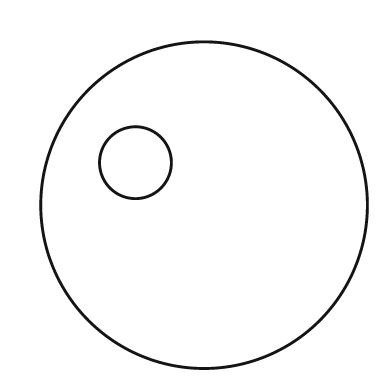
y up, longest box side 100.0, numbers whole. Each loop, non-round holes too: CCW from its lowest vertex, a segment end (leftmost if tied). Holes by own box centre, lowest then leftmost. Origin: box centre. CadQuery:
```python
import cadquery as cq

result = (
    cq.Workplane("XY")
    .moveTo(0.0, 0.0)
    .circle(50.0)
    .moveTo(-21.0, 13.0)
    .circle(11.0)
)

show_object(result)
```